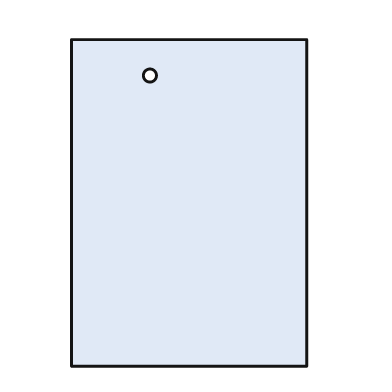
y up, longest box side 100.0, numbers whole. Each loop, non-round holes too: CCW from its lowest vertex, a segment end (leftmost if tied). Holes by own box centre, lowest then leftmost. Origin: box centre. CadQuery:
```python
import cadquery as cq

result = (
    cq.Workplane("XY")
    .moveTo(-36.0, -50.0)
    .lineTo(36.0, -50.0)
    .lineTo(36.0, 50.0)
    .lineTo(-36.0, 50.0)
    .close()
    .moveTo(-12.0, 39.0)
    .circle(2.0)
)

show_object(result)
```